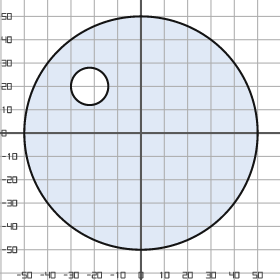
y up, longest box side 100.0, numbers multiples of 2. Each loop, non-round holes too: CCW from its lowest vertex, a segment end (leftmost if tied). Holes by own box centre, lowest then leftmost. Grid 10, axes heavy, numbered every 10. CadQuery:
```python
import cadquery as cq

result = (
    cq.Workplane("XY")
    .moveTo(0.0, 0.0)
    .circle(50.0)
    .moveTo(-22.0, 20.0)
    .circle(8.0)
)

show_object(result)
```